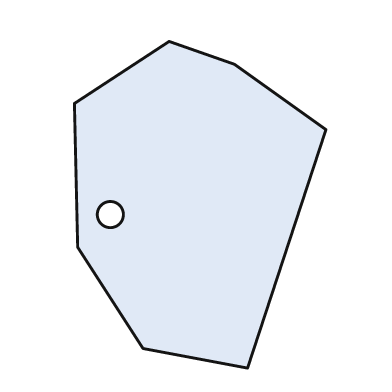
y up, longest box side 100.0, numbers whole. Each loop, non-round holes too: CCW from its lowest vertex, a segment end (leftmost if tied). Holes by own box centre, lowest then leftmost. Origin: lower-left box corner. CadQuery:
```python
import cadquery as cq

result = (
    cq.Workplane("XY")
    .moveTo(53.0, 0.0)
    .lineTo(77.0, 73.0)
    .lineTo(49.0, 93.0)
    .lineTo(29.0, 100.0)
    .lineTo(0.0, 81.0)
    .lineTo(1.0, 37.0)
    .lineTo(21.0, 6.0)
    .close()
    .moveTo(11.0, 47.0)
    .circle(4.0)
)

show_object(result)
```